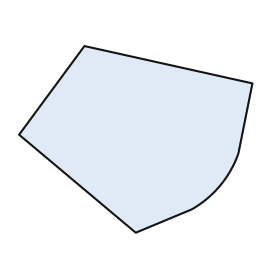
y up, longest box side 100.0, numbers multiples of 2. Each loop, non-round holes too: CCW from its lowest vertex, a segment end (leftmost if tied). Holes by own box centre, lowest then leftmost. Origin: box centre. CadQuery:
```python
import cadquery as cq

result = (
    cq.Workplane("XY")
    .moveTo(0.0, -40.0)
    .lineTo(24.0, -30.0)
    .threePointArc((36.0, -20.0), (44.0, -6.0))
    .lineTo(50.0, 24.0)
    .lineTo(-22.0, 40.0)
    .lineTo(-50.0, 2.0)
    .close()
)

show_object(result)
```